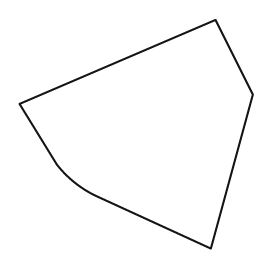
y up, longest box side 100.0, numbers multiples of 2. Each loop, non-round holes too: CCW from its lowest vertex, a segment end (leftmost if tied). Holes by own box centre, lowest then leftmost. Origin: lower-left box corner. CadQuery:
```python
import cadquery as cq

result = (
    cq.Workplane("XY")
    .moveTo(82.0, 0.0)
    .lineTo(100.0, 66.0)
    .lineTo(84.0, 98.0)
    .lineTo(0.0, 62.0)
    .lineTo(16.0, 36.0)
    .threePointArc((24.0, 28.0), (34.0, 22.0))
    .close()
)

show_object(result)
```